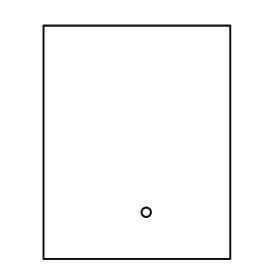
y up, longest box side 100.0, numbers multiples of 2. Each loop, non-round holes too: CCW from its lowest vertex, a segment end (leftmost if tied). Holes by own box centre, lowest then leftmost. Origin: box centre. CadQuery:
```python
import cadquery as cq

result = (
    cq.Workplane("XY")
    .moveTo(-40.0, -50.0)
    .lineTo(40.0, -50.0)
    .lineTo(40.0, 50.0)
    .lineTo(-40.0, 50.0)
    .close()
    .moveTo(4.0, -30.0)
    .circle(2.0)
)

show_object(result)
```